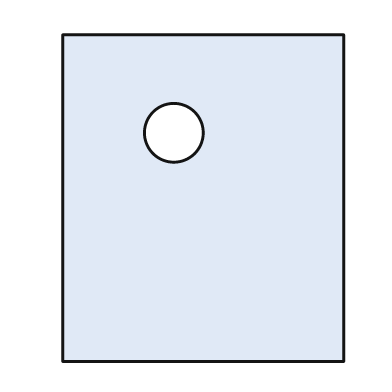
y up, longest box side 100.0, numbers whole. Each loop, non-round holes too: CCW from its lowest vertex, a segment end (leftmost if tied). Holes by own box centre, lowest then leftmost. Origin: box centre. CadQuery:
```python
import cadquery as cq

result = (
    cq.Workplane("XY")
    .moveTo(-43.0, -50.0)
    .lineTo(43.0, -50.0)
    .lineTo(43.0, 50.0)
    .lineTo(-43.0, 50.0)
    .close()
    .moveTo(-9.0, 20.0)
    .circle(9.0)
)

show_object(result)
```